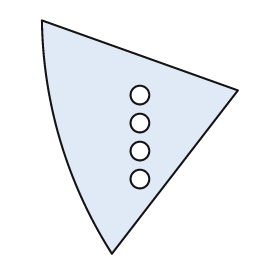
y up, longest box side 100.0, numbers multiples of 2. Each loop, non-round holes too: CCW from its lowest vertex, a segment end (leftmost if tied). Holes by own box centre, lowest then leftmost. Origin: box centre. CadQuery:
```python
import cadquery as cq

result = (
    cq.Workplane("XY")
    .moveTo(-12.0, -50.0)
    .lineTo(42.0, 20.0)
    .lineTo(-42.0, 50.0)
    .threePointArc((-34.0, -2.0), (-12.0, -50.0))
    .close()
    .moveTo(0.0, -18.0)
    .circle(4.0)
    .moveTo(0.0, -6.0)
    .circle(4.0)
    .moveTo(0.0, 6.0)
    .circle(4.0)
    .moveTo(0.0, 18.0)
    .circle(4.0)
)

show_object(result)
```